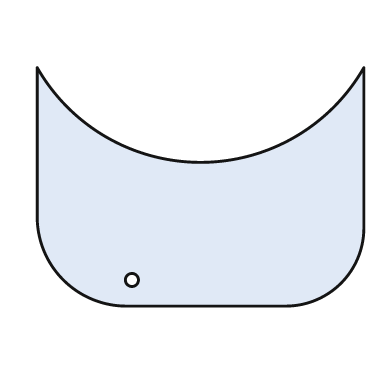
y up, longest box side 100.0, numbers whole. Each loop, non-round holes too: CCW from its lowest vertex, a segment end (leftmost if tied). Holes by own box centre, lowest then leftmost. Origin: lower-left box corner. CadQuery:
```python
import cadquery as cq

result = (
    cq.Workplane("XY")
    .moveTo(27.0, 0.0)
    .lineTo(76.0, 0.0)
    .threePointArc((93.0, 7.0), (100.0, 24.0))
    .lineTo(100.0, 73.0)
    .threePointArc((50.0, 44.0), (0.0, 73.0))
    .lineTo(0.0, 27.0)
    .threePointArc((8.0, 8.0), (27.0, 0.0))
    .close()
    .moveTo(29.0, 8.0)
    .circle(2.0)
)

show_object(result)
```